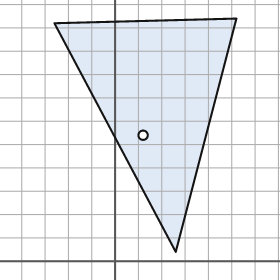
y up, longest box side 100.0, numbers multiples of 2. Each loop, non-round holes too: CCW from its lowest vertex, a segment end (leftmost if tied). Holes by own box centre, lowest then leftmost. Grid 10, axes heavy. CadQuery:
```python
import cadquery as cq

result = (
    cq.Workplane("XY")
    .moveTo(26.0, 4.0)
    .lineTo(52.0, 104.0)
    .lineTo(-26.0, 102.0)
    .close()
    .moveTo(12.0, 54.0)
    .circle(2.0)
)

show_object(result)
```